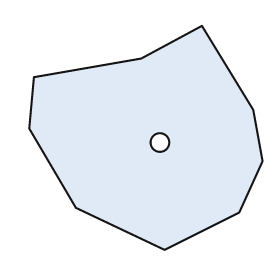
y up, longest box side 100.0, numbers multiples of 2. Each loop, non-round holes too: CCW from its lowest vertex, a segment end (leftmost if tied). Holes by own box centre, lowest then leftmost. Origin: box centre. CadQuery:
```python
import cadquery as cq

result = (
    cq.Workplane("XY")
    .moveTo(8.0, -48.0)
    .lineTo(40.0, -32.0)
    .lineTo(50.0, -10.0)
    .lineTo(46.0, 12.0)
    .lineTo(24.0, 48.0)
    .lineTo(-2.0, 34.0)
    .lineTo(-48.0, 26.0)
    .lineTo(-50.0, 4.0)
    .lineTo(-30.0, -30.0)
    .close()
    .moveTo(6.0, -2.0)
    .circle(4.0)
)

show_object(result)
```